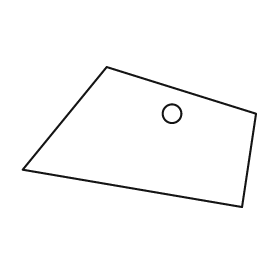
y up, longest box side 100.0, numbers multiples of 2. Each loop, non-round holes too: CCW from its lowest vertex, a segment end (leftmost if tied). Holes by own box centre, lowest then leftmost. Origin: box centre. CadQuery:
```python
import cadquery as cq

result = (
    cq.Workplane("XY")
    .moveTo(44.0, -30.0)
    .lineTo(50.0, 10.0)
    .lineTo(-14.0, 30.0)
    .lineTo(-50.0, -14.0)
    .close()
    .moveTo(14.0, 10.0)
    .circle(4.0)
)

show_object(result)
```